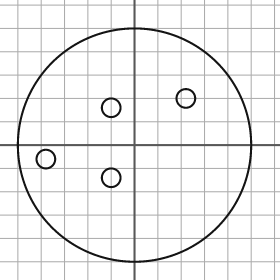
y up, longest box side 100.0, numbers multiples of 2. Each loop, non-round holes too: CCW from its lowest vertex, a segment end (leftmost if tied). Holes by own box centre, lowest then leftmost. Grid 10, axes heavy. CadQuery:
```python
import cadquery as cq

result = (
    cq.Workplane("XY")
    .moveTo(0.0, 0.0)
    .circle(50.0)
    .moveTo(-10.0, -14.0)
    .circle(4.0)
    .moveTo(-38.0, -6.0)
    .circle(4.0)
    .moveTo(-10.0, 16.0)
    .circle(4.0)
    .moveTo(22.0, 20.0)
    .circle(4.0)
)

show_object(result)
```